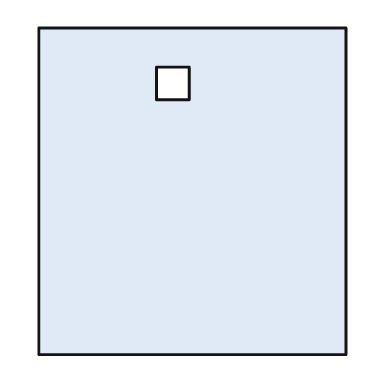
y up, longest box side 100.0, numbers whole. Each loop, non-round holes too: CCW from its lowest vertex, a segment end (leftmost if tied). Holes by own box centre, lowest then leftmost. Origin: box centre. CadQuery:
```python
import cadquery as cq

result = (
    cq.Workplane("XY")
    .moveTo(-47.0, -50.0)
    .lineTo(47.0, -50.0)
    .lineTo(47.0, 50.0)
    .lineTo(-47.0, 50.0)
    .close()
    .moveTo(-11.0, 28.0)
    .lineTo(-1.0, 28.0)
    .lineTo(-1.0, 38.0)
    .lineTo(-11.0, 38.0)
    .close()
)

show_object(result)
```